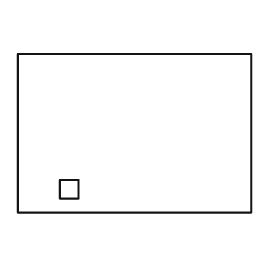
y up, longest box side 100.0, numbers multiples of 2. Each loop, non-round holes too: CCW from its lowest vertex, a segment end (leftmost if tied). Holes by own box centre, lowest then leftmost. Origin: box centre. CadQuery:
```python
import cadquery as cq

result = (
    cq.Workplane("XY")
    .moveTo(-50.0, -34.0)
    .lineTo(50.0, -34.0)
    .lineTo(50.0, 34.0)
    .lineTo(-50.0, 34.0)
    .close()
    .moveTo(-32.0, -28.0)
    .lineTo(-24.0, -28.0)
    .lineTo(-24.0, -20.0)
    .lineTo(-32.0, -20.0)
    .close()
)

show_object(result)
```